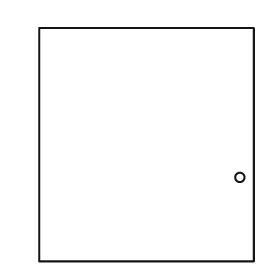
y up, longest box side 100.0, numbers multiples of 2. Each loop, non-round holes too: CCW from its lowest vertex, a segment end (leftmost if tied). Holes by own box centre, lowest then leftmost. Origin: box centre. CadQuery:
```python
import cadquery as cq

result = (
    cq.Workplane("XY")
    .moveTo(-46.0, -50.0)
    .lineTo(46.0, -50.0)
    .lineTo(46.0, 50.0)
    .lineTo(-46.0, 50.0)
    .close()
    .moveTo(40.0, -14.0)
    .circle(2.0)
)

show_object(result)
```